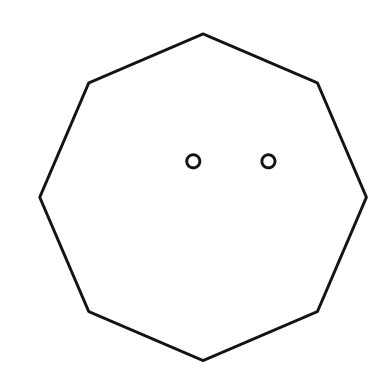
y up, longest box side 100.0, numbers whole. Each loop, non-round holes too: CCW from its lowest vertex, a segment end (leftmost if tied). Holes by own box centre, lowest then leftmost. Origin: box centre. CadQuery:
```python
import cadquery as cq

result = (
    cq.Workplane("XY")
    .moveTo(0.0, -50.0)
    .lineTo(35.0, -35.0)
    .lineTo(50.0, 0.0)
    .lineTo(35.0, 35.0)
    .lineTo(0.0, 50.0)
    .lineTo(-35.0, 35.0)
    .lineTo(-50.0, 0.0)
    .lineTo(-35.0, -35.0)
    .close()
    .moveTo(-3.0, 11.0)
    .circle(2.0)
    .moveTo(20.0, 11.0)
    .circle(2.0)
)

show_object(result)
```